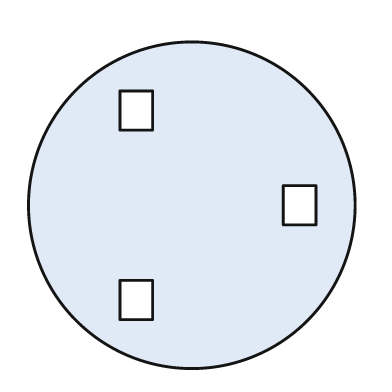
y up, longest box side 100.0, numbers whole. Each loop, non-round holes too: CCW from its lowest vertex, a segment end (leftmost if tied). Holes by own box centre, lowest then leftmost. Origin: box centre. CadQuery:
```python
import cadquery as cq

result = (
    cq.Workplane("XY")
    .moveTo(0.0, 0.0)
    .circle(50.0)
    .moveTo(-22.0, -35.0)
    .lineTo(-12.0, -35.0)
    .lineTo(-12.0, -23.0)
    .lineTo(-22.0, -23.0)
    .close()
    .moveTo(28.0, -6.0)
    .lineTo(38.0, -6.0)
    .lineTo(38.0, 6.0)
    .lineTo(28.0, 6.0)
    .close()
    .moveTo(-22.0, 23.0)
    .lineTo(-12.0, 23.0)
    .lineTo(-12.0, 35.0)
    .lineTo(-22.0, 35.0)
    .close()
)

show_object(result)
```